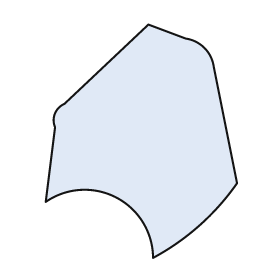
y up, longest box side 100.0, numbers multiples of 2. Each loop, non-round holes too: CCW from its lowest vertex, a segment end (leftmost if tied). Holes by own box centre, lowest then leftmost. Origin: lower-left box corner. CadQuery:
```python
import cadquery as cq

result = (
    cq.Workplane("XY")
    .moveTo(46.0, 0.0)
    .threePointArc((66.0, 14.0), (82.0, 32.0))
    .lineTo(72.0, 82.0)
    .threePointArc((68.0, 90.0), (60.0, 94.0))
    .lineTo(44.0, 100.0)
    .lineTo(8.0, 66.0)
    .threePointArc((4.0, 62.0), (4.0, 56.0))
    .lineTo(0.0, 24.0)
    .threePointArc((30.0, 26.0), (46.0, 0.0))
    .close()
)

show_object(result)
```